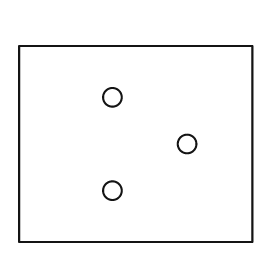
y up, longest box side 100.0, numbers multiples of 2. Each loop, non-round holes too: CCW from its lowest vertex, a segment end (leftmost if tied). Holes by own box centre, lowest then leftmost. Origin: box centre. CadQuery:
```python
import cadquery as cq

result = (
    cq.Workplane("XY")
    .moveTo(-50.0, -42.0)
    .lineTo(50.0, -42.0)
    .lineTo(50.0, 42.0)
    .lineTo(-50.0, 42.0)
    .close()
    .moveTo(-10.0, -20.0)
    .circle(4.0)
    .moveTo(22.0, 0.0)
    .circle(4.0)
    .moveTo(-10.0, 20.0)
    .circle(4.0)
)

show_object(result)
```